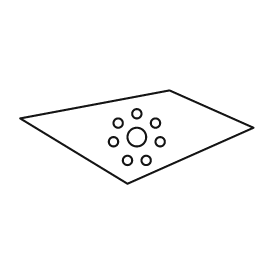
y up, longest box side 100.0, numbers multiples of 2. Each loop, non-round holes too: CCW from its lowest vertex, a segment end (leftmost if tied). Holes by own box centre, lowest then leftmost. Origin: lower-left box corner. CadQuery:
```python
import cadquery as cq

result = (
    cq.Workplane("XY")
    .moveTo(46.0, 0.0)
    .lineTo(100.0, 24.0)
    .lineTo(64.0, 40.0)
    .lineTo(0.0, 28.0)
    .close()
    .moveTo(46.0, 10.0)
    .circle(2.0)
    .moveTo(54.0, 10.0)
    .circle(2.0)
    .moveTo(40.0, 18.0)
    .circle(2.0)
    .moveTo(60.0, 18.0)
    .circle(2.0)
    .moveTo(50.0, 20.0)
    .circle(4.0)
    .moveTo(42.0, 26.0)
    .circle(2.0)
    .moveTo(58.0, 26.0)
    .circle(2.0)
    .moveTo(50.0, 30.0)
    .circle(2.0)
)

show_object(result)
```